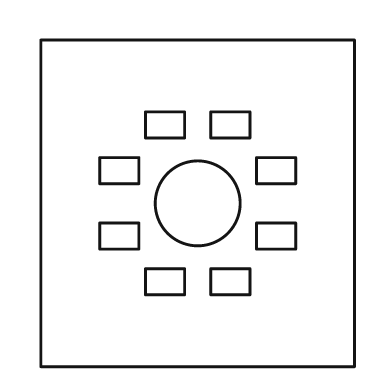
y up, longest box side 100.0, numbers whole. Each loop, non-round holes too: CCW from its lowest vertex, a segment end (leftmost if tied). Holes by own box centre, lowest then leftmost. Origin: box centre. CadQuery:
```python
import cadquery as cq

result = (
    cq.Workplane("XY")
    .moveTo(-48.0, -50.0)
    .lineTo(48.0, -50.0)
    .lineTo(48.0, 50.0)
    .lineTo(-48.0, 50.0)
    .close()
    .moveTo(-16.0, -28.0)
    .lineTo(-4.0, -28.0)
    .lineTo(-4.0, -20.0)
    .lineTo(-16.0, -20.0)
    .close()
    .moveTo(4.0, -28.0)
    .lineTo(16.0, -28.0)
    .lineTo(16.0, -20.0)
    .lineTo(4.0, -20.0)
    .close()
    .moveTo(-30.0, -14.0)
    .lineTo(-18.0, -14.0)
    .lineTo(-18.0, -6.0)
    .lineTo(-30.0, -6.0)
    .close()
    .moveTo(18.0, -14.0)
    .lineTo(30.0, -14.0)
    .lineTo(30.0, -6.0)
    .lineTo(18.0, -6.0)
    .close()
    .moveTo(0.0, 0.0)
    .circle(13.0)
    .moveTo(-30.0, 6.0)
    .lineTo(-18.0, 6.0)
    .lineTo(-18.0, 14.0)
    .lineTo(-30.0, 14.0)
    .close()
    .moveTo(18.0, 6.0)
    .lineTo(30.0, 6.0)
    .lineTo(30.0, 14.0)
    .lineTo(18.0, 14.0)
    .close()
    .moveTo(-16.0, 20.0)
    .lineTo(-4.0, 20.0)
    .lineTo(-4.0, 28.0)
    .lineTo(-16.0, 28.0)
    .close()
    .moveTo(4.0, 20.0)
    .lineTo(16.0, 20.0)
    .lineTo(16.0, 28.0)
    .lineTo(4.0, 28.0)
    .close()
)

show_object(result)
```